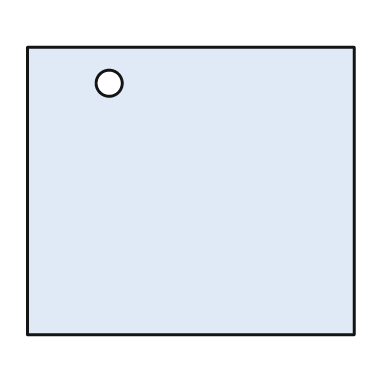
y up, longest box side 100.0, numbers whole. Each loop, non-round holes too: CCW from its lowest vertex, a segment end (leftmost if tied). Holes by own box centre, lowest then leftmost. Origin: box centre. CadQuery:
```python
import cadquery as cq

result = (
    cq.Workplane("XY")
    .moveTo(-50.0, -44.0)
    .lineTo(50.0, -44.0)
    .lineTo(50.0, 44.0)
    .lineTo(-50.0, 44.0)
    .close()
    .moveTo(-25.0, 33.0)
    .circle(4.0)
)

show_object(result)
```